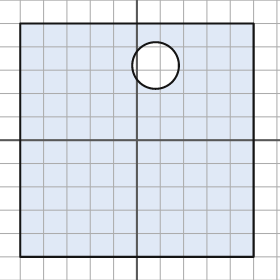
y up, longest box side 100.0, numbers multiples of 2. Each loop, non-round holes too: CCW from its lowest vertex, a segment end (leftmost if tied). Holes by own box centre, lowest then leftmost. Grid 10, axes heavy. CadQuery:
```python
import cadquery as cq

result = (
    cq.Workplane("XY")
    .moveTo(-50.0, -50.0)
    .lineTo(50.0, -50.0)
    .lineTo(50.0, 50.0)
    .lineTo(-50.0, 50.0)
    .close()
    .moveTo(8.0, 32.0)
    .circle(10.0)
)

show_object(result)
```